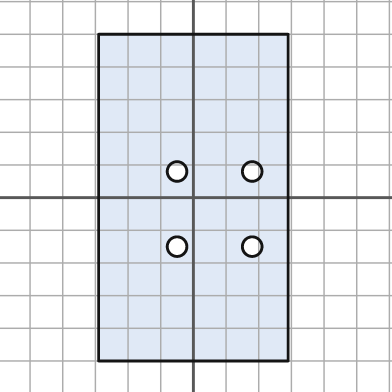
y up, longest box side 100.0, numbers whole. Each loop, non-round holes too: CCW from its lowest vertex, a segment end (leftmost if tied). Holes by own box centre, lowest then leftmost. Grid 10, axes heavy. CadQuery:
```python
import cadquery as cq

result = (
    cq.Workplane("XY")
    .moveTo(-29.0, -50.0)
    .lineTo(29.0, -50.0)
    .lineTo(29.0, 50.0)
    .lineTo(-29.0, 50.0)
    .close()
    .moveTo(-5.0, -15.0)
    .circle(3.0)
    .moveTo(18.0, -15.0)
    .circle(3.0)
    .moveTo(-5.0, 8.0)
    .circle(3.0)
    .moveTo(18.0, 8.0)
    .circle(3.0)
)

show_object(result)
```